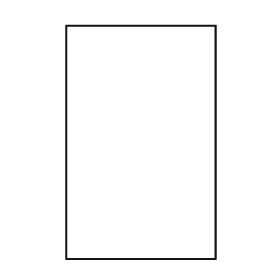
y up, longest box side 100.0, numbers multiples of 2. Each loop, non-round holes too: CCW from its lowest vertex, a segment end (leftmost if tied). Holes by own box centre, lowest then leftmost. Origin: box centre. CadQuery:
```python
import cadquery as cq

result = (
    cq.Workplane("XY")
    .moveTo(-32.0, -50.0)
    .lineTo(32.0, -50.0)
    .lineTo(32.0, 50.0)
    .lineTo(-32.0, 50.0)
    .close()
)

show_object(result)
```